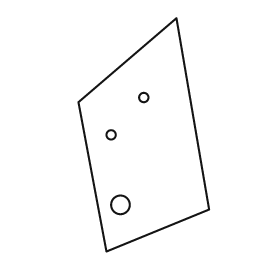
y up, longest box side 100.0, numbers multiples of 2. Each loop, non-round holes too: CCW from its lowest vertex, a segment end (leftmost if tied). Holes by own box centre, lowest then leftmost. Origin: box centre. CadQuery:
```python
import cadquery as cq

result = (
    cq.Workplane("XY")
    .moveTo(-16.0, -50.0)
    .lineTo(28.0, -32.0)
    .lineTo(14.0, 50.0)
    .lineTo(-28.0, 14.0)
    .close()
    .moveTo(-10.0, -30.0)
    .circle(4.0)
    .moveTo(-14.0, 0.0)
    .circle(2.0)
    .moveTo(0.0, 16.0)
    .circle(2.0)
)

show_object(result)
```